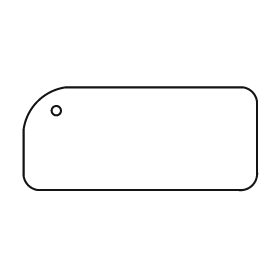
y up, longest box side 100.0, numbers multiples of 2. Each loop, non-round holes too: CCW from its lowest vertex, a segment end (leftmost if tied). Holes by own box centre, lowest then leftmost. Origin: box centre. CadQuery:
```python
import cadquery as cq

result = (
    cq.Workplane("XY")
    .moveTo(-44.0, -22.0)
    .lineTo(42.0, -22.0)
    .threePointArc((48.0, -20.0), (50.0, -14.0))
    .lineTo(50.0, 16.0)
    .threePointArc((48.0, 20.0), (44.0, 22.0))
    .lineTo(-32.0, 22.0)
    .threePointArc((-44.0, 16.0), (-50.0, 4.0))
    .lineTo(-50.0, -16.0)
    .threePointArc((-48.0, -20.0), (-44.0, -22.0))
    .close()
    .moveTo(-36.0, 12.0)
    .circle(2.0)
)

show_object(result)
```